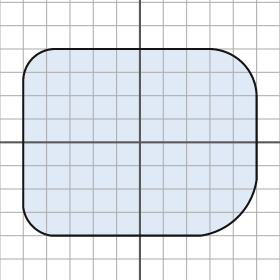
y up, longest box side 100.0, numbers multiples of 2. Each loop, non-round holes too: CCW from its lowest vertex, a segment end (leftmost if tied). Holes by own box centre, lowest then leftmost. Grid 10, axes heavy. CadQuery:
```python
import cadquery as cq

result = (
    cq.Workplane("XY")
    .moveTo(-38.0, -40.0)
    .lineTo(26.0, -40.0)
    .threePointArc((42.0, -32.0), (50.0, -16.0))
    .lineTo(50.0, 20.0)
    .threePointArc((44.0, 34.0), (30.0, 40.0))
    .lineTo(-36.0, 40.0)
    .threePointArc((-46.0, 36.0), (-50.0, 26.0))
    .lineTo(-50.0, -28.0)
    .threePointArc((-46.0, -36.0), (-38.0, -40.0))
    .close()
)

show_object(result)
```